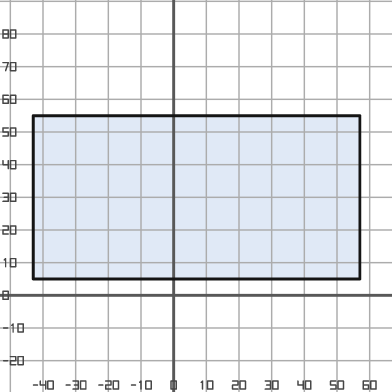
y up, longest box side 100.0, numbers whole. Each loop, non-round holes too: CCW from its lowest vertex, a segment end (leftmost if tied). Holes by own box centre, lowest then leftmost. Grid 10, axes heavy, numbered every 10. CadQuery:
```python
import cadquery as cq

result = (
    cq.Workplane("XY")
    .moveTo(-43.0, 5.0)
    .lineTo(57.0, 5.0)
    .lineTo(57.0, 55.0)
    .lineTo(-43.0, 55.0)
    .close()
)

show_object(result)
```